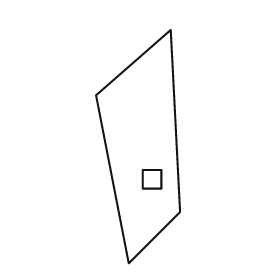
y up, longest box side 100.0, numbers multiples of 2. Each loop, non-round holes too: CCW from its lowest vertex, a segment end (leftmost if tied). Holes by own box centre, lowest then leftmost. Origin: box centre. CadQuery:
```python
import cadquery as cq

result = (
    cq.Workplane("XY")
    .moveTo(-4.0, -50.0)
    .lineTo(18.0, -28.0)
    .lineTo(14.0, 50.0)
    .lineTo(-18.0, 22.0)
    .close()
    .moveTo(2.0, -18.0)
    .lineTo(10.0, -18.0)
    .lineTo(10.0, -10.0)
    .lineTo(2.0, -10.0)
    .close()
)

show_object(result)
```